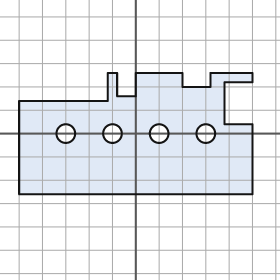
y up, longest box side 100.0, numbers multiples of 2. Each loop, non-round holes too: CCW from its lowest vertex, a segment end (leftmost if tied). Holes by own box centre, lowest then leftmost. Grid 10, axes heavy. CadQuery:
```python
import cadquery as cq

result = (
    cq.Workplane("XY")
    .moveTo(-50.0, -26.0)
    .lineTo(50.0, -26.0)
    .lineTo(50.0, 4.0)
    .lineTo(38.0, 4.0)
    .lineTo(38.0, 22.0)
    .lineTo(50.0, 22.0)
    .lineTo(50.0, 26.0)
    .lineTo(32.0, 26.0)
    .lineTo(32.0, 20.0)
    .lineTo(20.0, 20.0)
    .lineTo(20.0, 26.0)
    .lineTo(0.0, 26.0)
    .lineTo(0.0, 16.0)
    .lineTo(-8.0, 16.0)
    .lineTo(-8.0, 26.0)
    .lineTo(-12.0, 26.0)
    .lineTo(-12.0, 14.0)
    .lineTo(-50.0, 14.0)
    .close()
    .moveTo(-30.0, 0.0)
    .circle(4.0)
    .moveTo(-10.0, 0.0)
    .circle(4.0)
    .moveTo(10.0, 0.0)
    .circle(4.0)
    .moveTo(30.0, 0.0)
    .circle(4.0)
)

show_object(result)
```